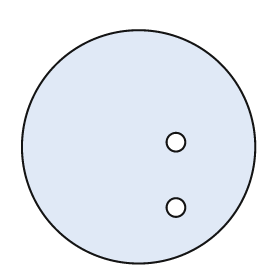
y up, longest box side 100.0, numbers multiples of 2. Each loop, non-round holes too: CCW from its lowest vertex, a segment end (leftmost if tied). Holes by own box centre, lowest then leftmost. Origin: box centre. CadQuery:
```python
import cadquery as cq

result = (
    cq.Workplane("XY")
    .moveTo(0.0, 0.0)
    .circle(50.0)
    .moveTo(16.0, -26.0)
    .circle(4.0)
    .moveTo(16.0, 2.0)
    .circle(4.0)
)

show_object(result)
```